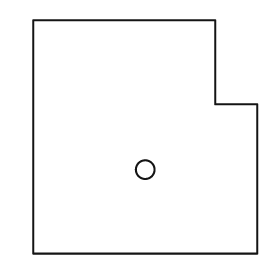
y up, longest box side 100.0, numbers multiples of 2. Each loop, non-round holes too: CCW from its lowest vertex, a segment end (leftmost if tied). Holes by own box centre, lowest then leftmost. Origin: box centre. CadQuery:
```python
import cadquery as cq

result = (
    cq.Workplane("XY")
    .moveTo(-48.0, -50.0)
    .lineTo(48.0, -50.0)
    .lineTo(48.0, 14.0)
    .lineTo(30.0, 14.0)
    .lineTo(30.0, 50.0)
    .lineTo(-48.0, 50.0)
    .close()
    .moveTo(0.0, -14.0)
    .circle(4.0)
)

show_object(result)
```